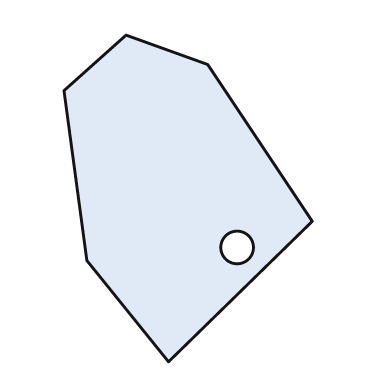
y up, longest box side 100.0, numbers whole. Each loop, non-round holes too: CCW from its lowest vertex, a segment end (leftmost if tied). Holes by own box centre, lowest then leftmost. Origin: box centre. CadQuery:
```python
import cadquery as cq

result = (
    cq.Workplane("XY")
    .moveTo(-6.0, -50.0)
    .lineTo(38.0, -7.0)
    .lineTo(6.0, 41.0)
    .lineTo(-19.0, 50.0)
    .lineTo(-38.0, 33.0)
    .lineTo(-31.0, -19.0)
    .close()
    .moveTo(15.0, -15.0)
    .circle(5.0)
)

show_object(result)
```